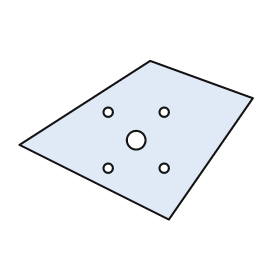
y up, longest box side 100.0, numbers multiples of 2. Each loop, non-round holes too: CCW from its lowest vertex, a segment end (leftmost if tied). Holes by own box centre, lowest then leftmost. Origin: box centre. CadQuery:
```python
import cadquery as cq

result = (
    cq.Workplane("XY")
    .moveTo(14.0, -34.0)
    .lineTo(50.0, 18.0)
    .lineTo(6.0, 34.0)
    .lineTo(-50.0, -2.0)
    .close()
    .moveTo(-12.0, -12.0)
    .circle(2.0)
    .moveTo(12.0, -12.0)
    .circle(2.0)
    .moveTo(0.0, 0.0)
    .circle(4.0)
    .moveTo(-12.0, 12.0)
    .circle(2.0)
    .moveTo(12.0, 12.0)
    .circle(2.0)
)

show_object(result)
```